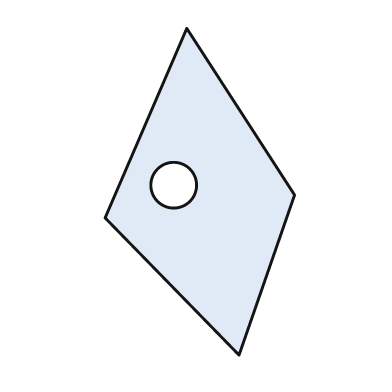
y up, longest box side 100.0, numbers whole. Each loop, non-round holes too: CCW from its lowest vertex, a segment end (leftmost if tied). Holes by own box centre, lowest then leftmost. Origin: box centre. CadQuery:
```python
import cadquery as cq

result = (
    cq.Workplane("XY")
    .moveTo(12.0, -50.0)
    .lineTo(29.0, -1.0)
    .lineTo(-4.0, 50.0)
    .lineTo(-29.0, -8.0)
    .close()
    .moveTo(-8.0, 2.0)
    .circle(7.0)
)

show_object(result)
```